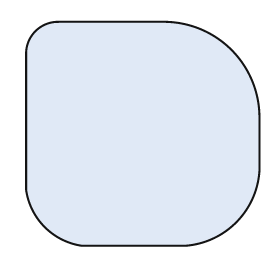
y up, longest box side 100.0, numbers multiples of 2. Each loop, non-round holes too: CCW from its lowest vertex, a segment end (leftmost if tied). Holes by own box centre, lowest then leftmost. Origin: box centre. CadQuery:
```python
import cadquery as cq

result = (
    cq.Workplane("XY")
    .moveTo(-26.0, -48.0)
    .lineTo(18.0, -48.0)
    .threePointArc((40.0, -38.0), (50.0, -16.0))
    .lineTo(50.0, 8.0)
    .threePointArc((38.0, 36.0), (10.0, 48.0))
    .lineTo(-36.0, 48.0)
    .threePointArc((-46.0, 44.0), (-50.0, 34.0))
    .lineTo(-50.0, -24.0)
    .threePointArc((-42.0, -40.0), (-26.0, -48.0))
    .close()
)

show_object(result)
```